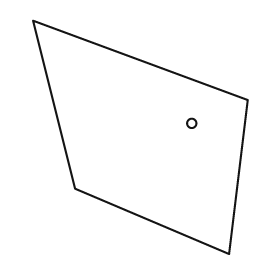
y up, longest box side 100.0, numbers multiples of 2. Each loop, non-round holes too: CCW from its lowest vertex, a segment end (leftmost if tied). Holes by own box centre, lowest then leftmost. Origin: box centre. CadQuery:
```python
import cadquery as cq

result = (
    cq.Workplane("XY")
    .moveTo(38.0, -50.0)
    .lineTo(46.0, 16.0)
    .lineTo(-46.0, 50.0)
    .lineTo(-28.0, -22.0)
    .close()
    .moveTo(22.0, 6.0)
    .circle(2.0)
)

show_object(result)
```